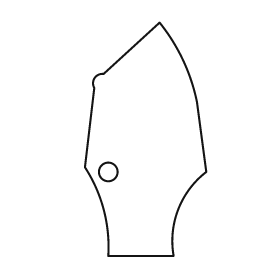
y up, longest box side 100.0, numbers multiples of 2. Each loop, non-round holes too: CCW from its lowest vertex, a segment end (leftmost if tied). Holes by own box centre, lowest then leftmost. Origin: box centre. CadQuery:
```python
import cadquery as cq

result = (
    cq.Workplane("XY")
    .moveTo(-16.0, -50.0)
    .lineTo(12.0, -50.0)
    .threePointArc((14.0, -30.0), (26.0, -14.0))
    .lineTo(22.0, 16.0)
    .threePointArc((16.0, 34.0), (6.0, 50.0))
    .lineTo(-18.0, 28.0)
    .threePointArc((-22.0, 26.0), (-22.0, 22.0))
    .lineTo(-26.0, -12.0)
    .threePointArc((-18.0, -30.0), (-16.0, -50.0))
    .close()
    .moveTo(-16.0, -14.0)
    .circle(4.0)
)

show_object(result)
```